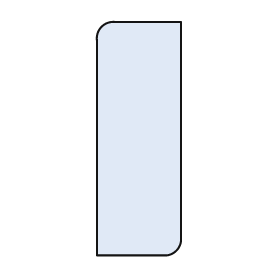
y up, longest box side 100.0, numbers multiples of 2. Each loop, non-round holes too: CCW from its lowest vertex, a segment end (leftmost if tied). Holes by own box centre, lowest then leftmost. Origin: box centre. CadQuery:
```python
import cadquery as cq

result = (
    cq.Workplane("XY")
    .moveTo(-18.0, -50.0)
    .lineTo(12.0, -50.0)
    .threePointArc((16.0, -48.0), (18.0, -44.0))
    .lineTo(18.0, 50.0)
    .lineTo(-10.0, 50.0)
    .threePointArc((-16.0, 48.0), (-18.0, 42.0))
    .close()
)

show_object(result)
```